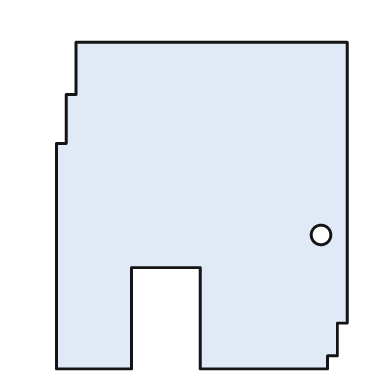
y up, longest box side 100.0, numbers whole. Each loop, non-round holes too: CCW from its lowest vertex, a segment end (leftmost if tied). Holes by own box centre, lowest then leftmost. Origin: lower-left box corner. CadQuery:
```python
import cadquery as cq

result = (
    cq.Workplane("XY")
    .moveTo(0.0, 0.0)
    .lineTo(23.0, 0.0)
    .lineTo(23.0, 31.0)
    .lineTo(44.0, 31.0)
    .lineTo(44.0, 0.0)
    .lineTo(83.0, 0.0)
    .lineTo(83.0, 4.0)
    .lineTo(86.0, 4.0)
    .lineTo(86.0, 14.0)
    .lineTo(89.0, 14.0)
    .lineTo(89.0, 100.0)
    .lineTo(6.0, 100.0)
    .lineTo(6.0, 84.0)
    .lineTo(3.0, 84.0)
    .lineTo(3.0, 69.0)
    .lineTo(0.0, 69.0)
    .close()
    .moveTo(81.0, 41.0)
    .circle(3.0)
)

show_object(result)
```